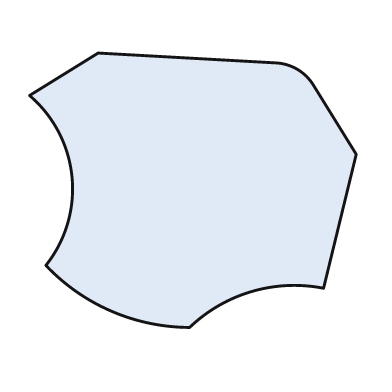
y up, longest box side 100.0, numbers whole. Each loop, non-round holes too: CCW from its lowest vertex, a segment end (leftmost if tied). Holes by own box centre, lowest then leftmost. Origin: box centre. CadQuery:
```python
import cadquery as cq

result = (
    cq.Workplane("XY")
    .moveTo(-1.0, -42.0)
    .threePointArc((18.0, -31.0), (40.0, -30.0))
    .lineTo(50.0, 11.0)
    .lineTo(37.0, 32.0)
    .threePointArc((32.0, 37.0), (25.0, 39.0))
    .lineTo(-29.0, 42.0)
    .lineTo(-50.0, 29.0)
    .threePointArc((-37.0, 4.0), (-45.0, -23.0))
    .threePointArc((-25.0, -37.0), (-1.0, -42.0))
    .close()
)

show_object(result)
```